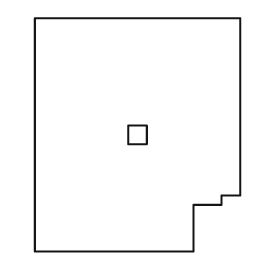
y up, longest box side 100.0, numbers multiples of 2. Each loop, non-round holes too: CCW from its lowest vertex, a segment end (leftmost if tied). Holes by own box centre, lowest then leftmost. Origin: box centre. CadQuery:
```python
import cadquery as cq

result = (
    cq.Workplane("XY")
    .moveTo(-44.0, -50.0)
    .lineTo(24.0, -50.0)
    .lineTo(24.0, -30.0)
    .lineTo(36.0, -30.0)
    .lineTo(36.0, -26.0)
    .lineTo(44.0, -26.0)
    .lineTo(44.0, 50.0)
    .lineTo(-44.0, 50.0)
    .close()
    .moveTo(-4.0, -4.0)
    .lineTo(4.0, -4.0)
    .lineTo(4.0, 4.0)
    .lineTo(-4.0, 4.0)
    .close()
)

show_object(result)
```